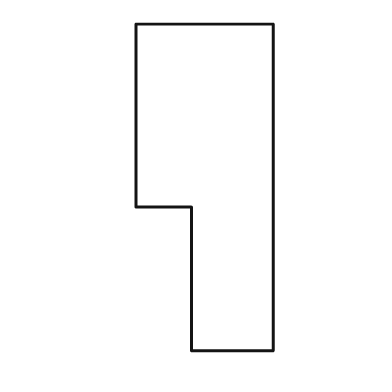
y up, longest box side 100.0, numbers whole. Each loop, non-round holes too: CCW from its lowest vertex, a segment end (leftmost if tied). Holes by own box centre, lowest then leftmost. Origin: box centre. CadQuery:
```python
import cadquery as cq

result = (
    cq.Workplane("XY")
    .moveTo(-4.0, -50.0)
    .lineTo(21.0, -50.0)
    .lineTo(21.0, 50.0)
    .lineTo(-21.0, 50.0)
    .lineTo(-21.0, -6.0)
    .lineTo(-4.0, -6.0)
    .close()
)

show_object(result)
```